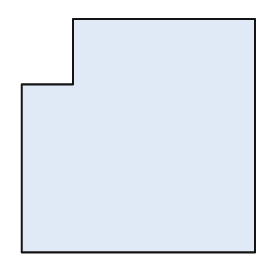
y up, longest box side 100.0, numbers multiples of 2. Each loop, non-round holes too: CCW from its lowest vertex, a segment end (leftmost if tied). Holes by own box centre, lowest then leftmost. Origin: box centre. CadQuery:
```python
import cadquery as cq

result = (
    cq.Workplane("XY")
    .moveTo(-50.0, -50.0)
    .lineTo(50.0, -50.0)
    .lineTo(50.0, 50.0)
    .lineTo(-28.0, 50.0)
    .lineTo(-28.0, 22.0)
    .lineTo(-50.0, 22.0)
    .close()
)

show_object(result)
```